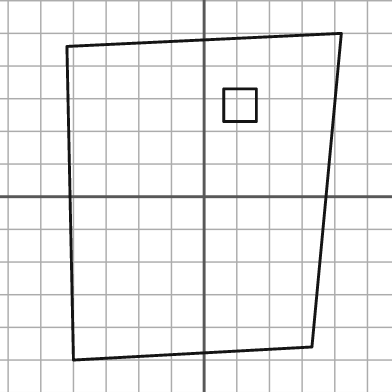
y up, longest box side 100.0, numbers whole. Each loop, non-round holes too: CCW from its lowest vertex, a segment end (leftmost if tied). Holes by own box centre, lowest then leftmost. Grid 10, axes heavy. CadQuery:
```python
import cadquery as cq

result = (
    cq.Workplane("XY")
    .moveTo(-40.0, -50.0)
    .lineTo(33.0, -46.0)
    .lineTo(42.0, 50.0)
    .lineTo(-42.0, 46.0)
    .close()
    .moveTo(6.0, 23.0)
    .lineTo(16.0, 23.0)
    .lineTo(16.0, 33.0)
    .lineTo(6.0, 33.0)
    .close()
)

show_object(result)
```